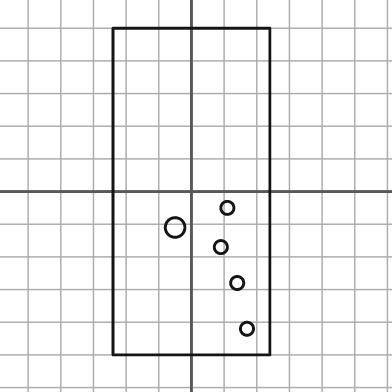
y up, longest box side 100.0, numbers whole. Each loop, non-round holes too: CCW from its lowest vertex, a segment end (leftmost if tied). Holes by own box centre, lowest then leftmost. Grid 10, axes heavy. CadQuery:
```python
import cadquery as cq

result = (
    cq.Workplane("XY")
    .moveTo(-24.0, -50.0)
    .lineTo(24.0, -50.0)
    .lineTo(24.0, 50.0)
    .lineTo(-24.0, 50.0)
    .close()
    .moveTo(17.0, -42.0)
    .circle(2.0)
    .moveTo(14.0, -28.0)
    .circle(2.0)
    .moveTo(9.0, -17.0)
    .circle(2.0)
    .moveTo(-5.0, -11.0)
    .circle(3.0)
    .moveTo(11.0, -5.0)
    .circle(2.0)
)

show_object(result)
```